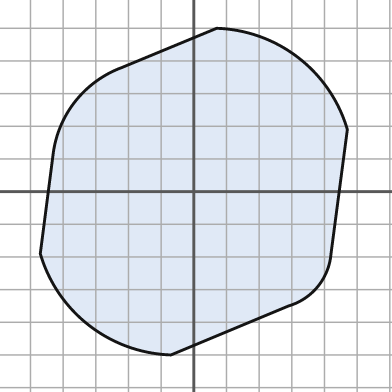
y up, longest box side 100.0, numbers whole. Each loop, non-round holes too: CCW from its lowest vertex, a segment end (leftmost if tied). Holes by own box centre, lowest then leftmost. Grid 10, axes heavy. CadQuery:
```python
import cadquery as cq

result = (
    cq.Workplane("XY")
    .moveTo(-7.0, -50.0)
    .lineTo(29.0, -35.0)
    .threePointArc((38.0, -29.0), (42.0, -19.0))
    .lineTo(47.0, 19.0)
    .threePointArc((32.0, 41.0), (7.0, 50.0))
    .lineTo(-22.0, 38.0)
    .threePointArc((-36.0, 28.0), (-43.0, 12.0))
    .lineTo(-47.0, -19.0)
    .threePointArc((-32.0, -41.0), (-7.0, -50.0))
    .close()
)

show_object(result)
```